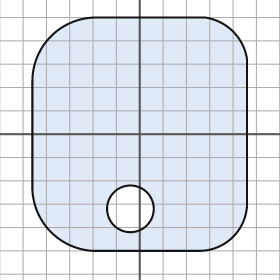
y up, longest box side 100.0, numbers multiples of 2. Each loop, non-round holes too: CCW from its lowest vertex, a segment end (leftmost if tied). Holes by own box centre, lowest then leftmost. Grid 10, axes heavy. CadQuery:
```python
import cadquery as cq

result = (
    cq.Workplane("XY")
    .moveTo(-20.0, -50.0)
    .lineTo(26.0, -50.0)
    .threePointArc((40.0, -44.0), (46.0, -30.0))
    .lineTo(46.0, 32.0)
    .threePointArc((40.0, 44.0), (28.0, 50.0))
    .lineTo(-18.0, 50.0)
    .threePointArc((-38.0, 42.0), (-46.0, 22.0))
    .lineTo(-46.0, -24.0)
    .threePointArc((-38.0, -42.0), (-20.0, -50.0))
    .close()
    .moveTo(-4.0, -32.0)
    .circle(10.0)
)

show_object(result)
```